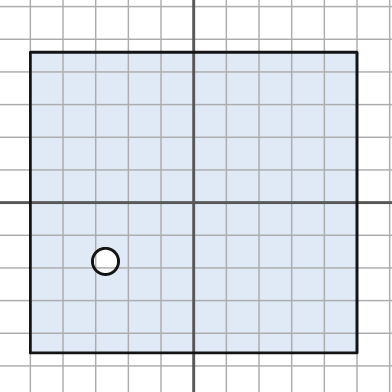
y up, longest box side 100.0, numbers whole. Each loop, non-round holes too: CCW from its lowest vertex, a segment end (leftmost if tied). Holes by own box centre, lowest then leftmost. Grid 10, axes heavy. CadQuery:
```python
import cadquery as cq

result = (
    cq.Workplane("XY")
    .moveTo(-50.0, -46.0)
    .lineTo(50.0, -46.0)
    .lineTo(50.0, 46.0)
    .lineTo(-50.0, 46.0)
    .close()
    .moveTo(-27.0, -18.0)
    .circle(4.0)
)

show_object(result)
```